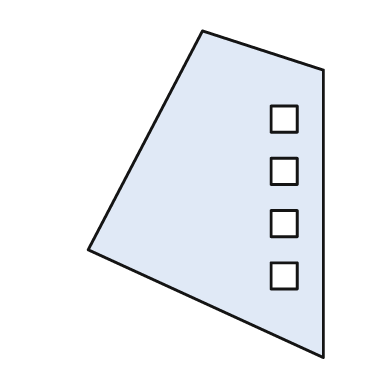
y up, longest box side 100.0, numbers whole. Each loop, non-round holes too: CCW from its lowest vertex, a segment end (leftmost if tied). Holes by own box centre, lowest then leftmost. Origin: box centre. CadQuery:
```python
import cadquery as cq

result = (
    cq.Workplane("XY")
    .moveTo(36.0, -50.0)
    .lineTo(36.0, 38.0)
    .lineTo(-1.0, 50.0)
    .lineTo(-36.0, -17.0)
    .close()
    .moveTo(20.0, -29.0)
    .lineTo(28.0, -29.0)
    .lineTo(28.0, -21.0)
    .lineTo(20.0, -21.0)
    .close()
    .moveTo(20.0, -13.0)
    .lineTo(28.0, -13.0)
    .lineTo(28.0, -5.0)
    .lineTo(20.0, -5.0)
    .close()
    .moveTo(20.0, 3.0)
    .lineTo(28.0, 3.0)
    .lineTo(28.0, 11.0)
    .lineTo(20.0, 11.0)
    .close()
    .moveTo(20.0, 19.0)
    .lineTo(28.0, 19.0)
    .lineTo(28.0, 27.0)
    .lineTo(20.0, 27.0)
    .close()
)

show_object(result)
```